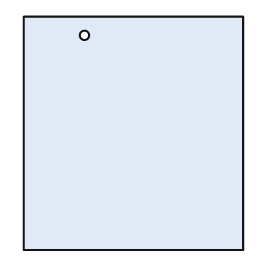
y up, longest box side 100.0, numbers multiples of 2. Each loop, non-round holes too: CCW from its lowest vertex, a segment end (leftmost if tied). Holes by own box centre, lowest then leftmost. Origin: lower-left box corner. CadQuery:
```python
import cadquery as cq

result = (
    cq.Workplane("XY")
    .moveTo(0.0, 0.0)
    .lineTo(94.0, 0.0)
    .lineTo(94.0, 100.0)
    .lineTo(0.0, 100.0)
    .close()
    .moveTo(26.0, 92.0)
    .circle(2.0)
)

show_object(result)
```